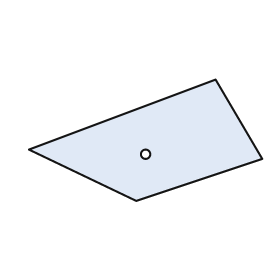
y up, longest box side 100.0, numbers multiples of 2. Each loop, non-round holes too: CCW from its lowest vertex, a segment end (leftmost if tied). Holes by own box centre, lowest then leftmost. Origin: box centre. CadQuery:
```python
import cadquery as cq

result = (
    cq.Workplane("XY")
    .moveTo(-4.0, -26.0)
    .lineTo(50.0, -8.0)
    .lineTo(30.0, 26.0)
    .lineTo(-50.0, -4.0)
    .close()
    .moveTo(0.0, -6.0)
    .circle(2.0)
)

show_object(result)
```